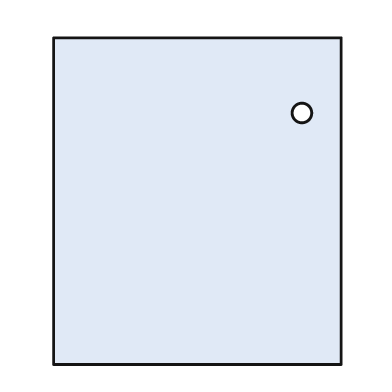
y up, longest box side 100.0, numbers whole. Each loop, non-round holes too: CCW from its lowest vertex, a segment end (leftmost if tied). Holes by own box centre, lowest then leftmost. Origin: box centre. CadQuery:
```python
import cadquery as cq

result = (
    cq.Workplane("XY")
    .moveTo(-44.0, -50.0)
    .lineTo(44.0, -50.0)
    .lineTo(44.0, 50.0)
    .lineTo(-44.0, 50.0)
    .close()
    .moveTo(32.0, 27.0)
    .circle(3.0)
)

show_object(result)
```